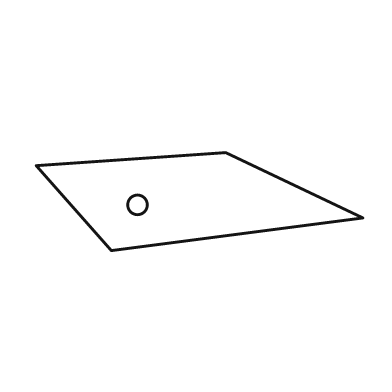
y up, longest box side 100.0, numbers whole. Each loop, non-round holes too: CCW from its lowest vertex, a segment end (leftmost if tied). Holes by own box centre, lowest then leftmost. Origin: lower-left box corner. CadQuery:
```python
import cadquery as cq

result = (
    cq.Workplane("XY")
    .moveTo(23.0, 0.0)
    .lineTo(100.0, 10.0)
    .lineTo(58.0, 30.0)
    .lineTo(0.0, 26.0)
    .close()
    .moveTo(31.0, 14.0)
    .circle(3.0)
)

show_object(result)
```